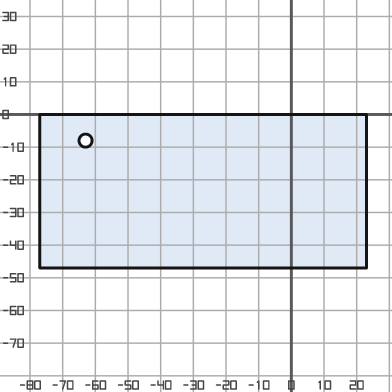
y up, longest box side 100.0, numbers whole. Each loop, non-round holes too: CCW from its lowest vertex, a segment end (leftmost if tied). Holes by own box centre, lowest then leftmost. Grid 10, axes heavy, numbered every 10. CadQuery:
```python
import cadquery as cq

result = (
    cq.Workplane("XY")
    .moveTo(-77.0, -47.0)
    .lineTo(23.0, -47.0)
    .lineTo(23.0, 0.0)
    .lineTo(-77.0, 0.0)
    .close()
    .moveTo(-63.0, -8.0)
    .circle(2.0)
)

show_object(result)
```